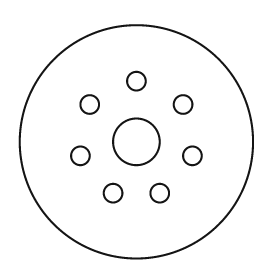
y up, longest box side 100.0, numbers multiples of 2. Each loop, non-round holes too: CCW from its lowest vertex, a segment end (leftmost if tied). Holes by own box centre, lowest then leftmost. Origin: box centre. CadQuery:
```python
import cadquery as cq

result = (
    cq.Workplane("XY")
    .moveTo(0.0, 0.0)
    .circle(50.0)
    .moveTo(-10.0, -22.0)
    .circle(4.0)
    .moveTo(10.0, -22.0)
    .circle(4.0)
    .moveTo(-24.0, -6.0)
    .circle(4.0)
    .moveTo(24.0, -6.0)
    .circle(4.0)
    .moveTo(0.0, 0.0)
    .circle(10.0)
    .moveTo(-20.0, 16.0)
    .circle(4.0)
    .moveTo(20.0, 16.0)
    .circle(4.0)
    .moveTo(0.0, 26.0)
    .circle(4.0)
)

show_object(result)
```